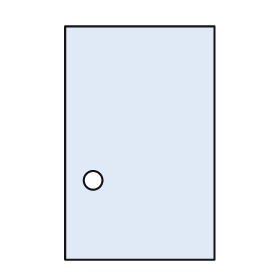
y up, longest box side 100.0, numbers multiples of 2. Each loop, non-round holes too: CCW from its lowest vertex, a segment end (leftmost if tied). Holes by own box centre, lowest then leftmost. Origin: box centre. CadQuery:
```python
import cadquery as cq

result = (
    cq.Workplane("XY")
    .moveTo(-32.0, -50.0)
    .lineTo(32.0, -50.0)
    .lineTo(32.0, 50.0)
    .lineTo(-32.0, 50.0)
    .close()
    .moveTo(-20.0, -16.0)
    .circle(4.0)
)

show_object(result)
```